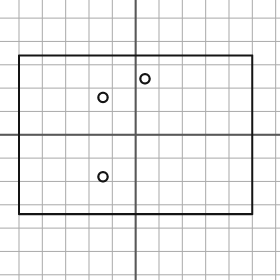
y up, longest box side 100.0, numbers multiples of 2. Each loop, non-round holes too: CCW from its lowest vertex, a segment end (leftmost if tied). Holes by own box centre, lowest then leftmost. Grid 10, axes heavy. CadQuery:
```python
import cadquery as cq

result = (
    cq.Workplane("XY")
    .moveTo(-50.0, -34.0)
    .lineTo(50.0, -34.0)
    .lineTo(50.0, 34.0)
    .lineTo(-50.0, 34.0)
    .close()
    .moveTo(-14.0, -18.0)
    .circle(2.0)
    .moveTo(-14.0, 16.0)
    .circle(2.0)
    .moveTo(4.0, 24.0)
    .circle(2.0)
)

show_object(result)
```